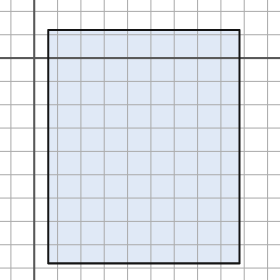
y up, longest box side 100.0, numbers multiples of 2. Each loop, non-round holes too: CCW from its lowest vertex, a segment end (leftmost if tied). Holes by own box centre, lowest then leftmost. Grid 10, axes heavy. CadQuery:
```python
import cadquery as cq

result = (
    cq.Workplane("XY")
    .moveTo(6.0, -88.0)
    .lineTo(88.0, -88.0)
    .lineTo(88.0, 12.0)
    .lineTo(6.0, 12.0)
    .close()
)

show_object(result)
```